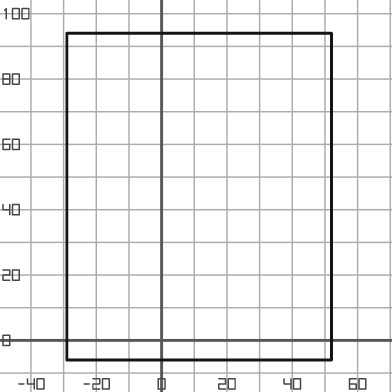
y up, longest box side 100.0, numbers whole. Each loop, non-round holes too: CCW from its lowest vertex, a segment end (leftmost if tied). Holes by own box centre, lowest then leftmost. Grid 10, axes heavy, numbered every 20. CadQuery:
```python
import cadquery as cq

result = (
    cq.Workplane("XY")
    .moveTo(-29.0, -6.0)
    .lineTo(52.0, -6.0)
    .lineTo(52.0, 94.0)
    .lineTo(-29.0, 94.0)
    .close()
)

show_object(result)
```